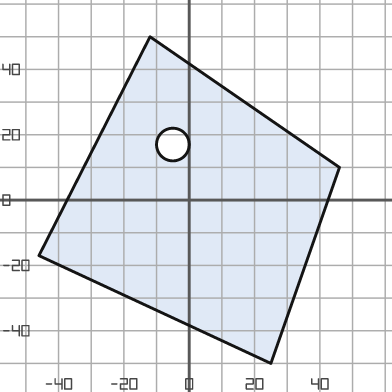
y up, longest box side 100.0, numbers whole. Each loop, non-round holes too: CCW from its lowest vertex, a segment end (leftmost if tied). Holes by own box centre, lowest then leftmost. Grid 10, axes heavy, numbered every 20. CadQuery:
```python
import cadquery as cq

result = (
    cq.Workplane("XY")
    .moveTo(25.0, -50.0)
    .lineTo(46.0, 10.0)
    .lineTo(-12.0, 50.0)
    .lineTo(-46.0, -17.0)
    .close()
    .moveTo(-5.0, 17.0)
    .circle(5.0)
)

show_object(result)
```